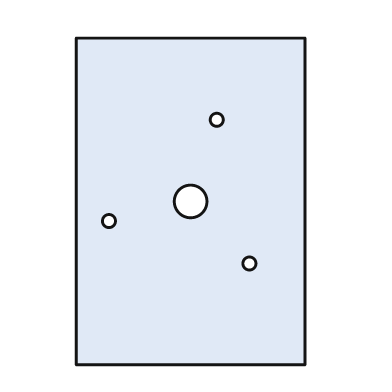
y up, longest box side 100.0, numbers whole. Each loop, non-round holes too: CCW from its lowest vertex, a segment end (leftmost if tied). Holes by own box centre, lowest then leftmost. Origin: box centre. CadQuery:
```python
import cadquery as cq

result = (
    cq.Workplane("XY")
    .moveTo(-35.0, -50.0)
    .lineTo(35.0, -50.0)
    .lineTo(35.0, 50.0)
    .lineTo(-35.0, 50.0)
    .close()
    .moveTo(18.0, -19.0)
    .circle(2.0)
    .moveTo(-25.0, -6.0)
    .circle(2.0)
    .moveTo(0.0, 0.0)
    .circle(5.0)
    .moveTo(8.0, 25.0)
    .circle(2.0)
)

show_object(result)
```